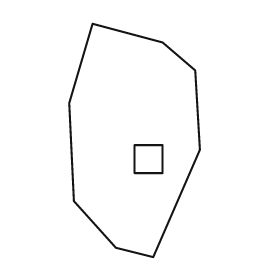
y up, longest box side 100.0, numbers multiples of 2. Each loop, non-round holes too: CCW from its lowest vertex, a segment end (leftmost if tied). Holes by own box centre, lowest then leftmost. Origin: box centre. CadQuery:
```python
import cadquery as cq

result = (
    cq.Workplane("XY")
    .moveTo(8.0, -50.0)
    .lineTo(28.0, -4.0)
    .lineTo(26.0, 30.0)
    .lineTo(12.0, 42.0)
    .lineTo(-18.0, 50.0)
    .lineTo(-28.0, 16.0)
    .lineTo(-26.0, -26.0)
    .lineTo(-8.0, -46.0)
    .close()
    .moveTo(0.0, -14.0)
    .lineTo(12.0, -14.0)
    .lineTo(12.0, -2.0)
    .lineTo(0.0, -2.0)
    .close()
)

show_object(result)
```